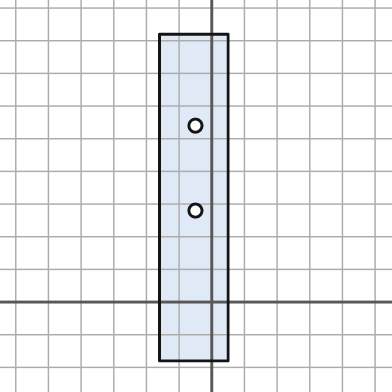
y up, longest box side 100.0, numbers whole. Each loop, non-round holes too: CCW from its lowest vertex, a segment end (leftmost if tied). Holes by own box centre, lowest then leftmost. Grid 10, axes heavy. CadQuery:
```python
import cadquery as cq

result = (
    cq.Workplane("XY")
    .moveTo(-16.0, -18.0)
    .lineTo(5.0, -18.0)
    .lineTo(5.0, 82.0)
    .lineTo(-16.0, 82.0)
    .close()
    .moveTo(-5.0, 28.0)
    .circle(2.0)
    .moveTo(-5.0, 54.0)
    .circle(2.0)
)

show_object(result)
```